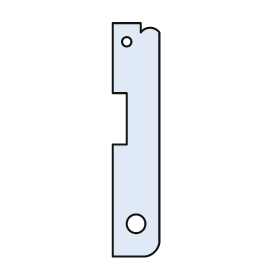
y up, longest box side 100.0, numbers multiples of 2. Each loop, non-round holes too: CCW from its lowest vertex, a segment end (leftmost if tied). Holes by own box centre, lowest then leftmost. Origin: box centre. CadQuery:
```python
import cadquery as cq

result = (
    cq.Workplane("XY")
    .moveTo(-10.0, -50.0)
    .lineTo(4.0, -50.0)
    .threePointArc((8.0, -48.0), (10.0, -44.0))
    .lineTo(10.0, 46.0)
    .threePointArc((6.0, 48.0), (2.0, 46.0))
    .lineTo(2.0, 50.0)
    .lineTo(-10.0, 50.0)
    .lineTo(-10.0, 20.0)
    .lineTo(-4.0, 20.0)
    .lineTo(-4.0, -2.0)
    .lineTo(-10.0, -2.0)
    .close()
    .moveTo(0.0, -36.0)
    .circle(4.0)
    .moveTo(-4.0, 42.0)
    .circle(2.0)
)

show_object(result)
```